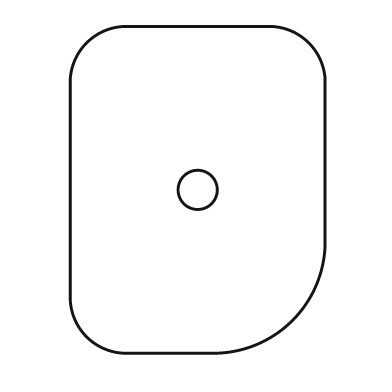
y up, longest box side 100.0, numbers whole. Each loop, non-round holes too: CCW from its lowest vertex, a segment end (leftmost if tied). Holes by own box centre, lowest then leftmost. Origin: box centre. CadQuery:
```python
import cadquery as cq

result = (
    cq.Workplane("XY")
    .moveTo(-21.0, -50.0)
    .lineTo(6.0, -50.0)
    .threePointArc((29.0, -40.0), (39.0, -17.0))
    .lineTo(39.0, 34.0)
    .threePointArc((34.0, 45.0), (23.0, 50.0))
    .lineTo(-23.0, 50.0)
    .threePointArc((-34.0, 45.0), (-39.0, 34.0))
    .lineTo(-39.0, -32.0)
    .threePointArc((-34.0, -45.0), (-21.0, -50.0))
    .close()
    .moveTo(0.0, 0.0)
    .circle(6.0)
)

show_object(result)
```